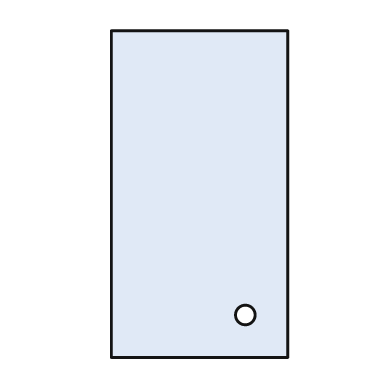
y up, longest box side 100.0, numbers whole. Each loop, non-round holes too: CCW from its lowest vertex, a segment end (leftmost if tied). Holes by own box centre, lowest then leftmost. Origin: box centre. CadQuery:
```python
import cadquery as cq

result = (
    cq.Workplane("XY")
    .moveTo(-27.0, -50.0)
    .lineTo(27.0, -50.0)
    .lineTo(27.0, 50.0)
    .lineTo(-27.0, 50.0)
    .close()
    .moveTo(14.0, -37.0)
    .circle(3.0)
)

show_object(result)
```